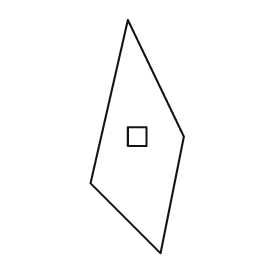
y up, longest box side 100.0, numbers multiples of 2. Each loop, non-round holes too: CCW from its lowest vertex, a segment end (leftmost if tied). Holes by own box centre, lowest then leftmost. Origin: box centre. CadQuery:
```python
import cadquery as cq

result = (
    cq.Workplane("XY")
    .moveTo(10.0, -50.0)
    .lineTo(20.0, 0.0)
    .lineTo(-4.0, 50.0)
    .lineTo(-20.0, -20.0)
    .close()
    .moveTo(-4.0, -4.0)
    .lineTo(4.0, -4.0)
    .lineTo(4.0, 4.0)
    .lineTo(-4.0, 4.0)
    .close()
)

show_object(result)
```